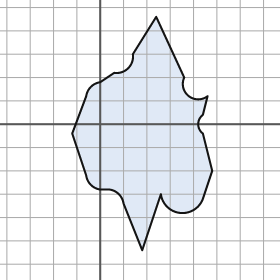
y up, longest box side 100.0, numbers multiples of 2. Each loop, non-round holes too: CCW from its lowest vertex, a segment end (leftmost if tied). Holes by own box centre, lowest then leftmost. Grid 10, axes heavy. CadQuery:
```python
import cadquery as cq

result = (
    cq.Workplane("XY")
    .moveTo(18.0, -54.0)
    .lineTo(26.0, -30.0)
    .threePointArc((34.0, -38.0), (44.0, -32.0))
    .lineTo(48.0, -20.0)
    .lineTo(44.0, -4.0)
    .threePointArc((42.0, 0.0), (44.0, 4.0))
    .lineTo(46.0, 12.0)
    .threePointArc((38.0, 12.0), (36.0, 20.0))
    .lineTo(24.0, 46.0)
    .lineTo(14.0, 30.0)
    .threePointArc((12.0, 24.0), (6.0, 22.0))
    .lineTo(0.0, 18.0)
    .threePointArc((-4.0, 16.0), (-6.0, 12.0))
    .lineTo(-12.0, -4.0)
    .lineTo(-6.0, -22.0)
    .threePointArc((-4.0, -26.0), (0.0, -28.0))
    .lineTo(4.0, -28.0)
    .threePointArc((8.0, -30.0), (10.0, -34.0))
    .close()
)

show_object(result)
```